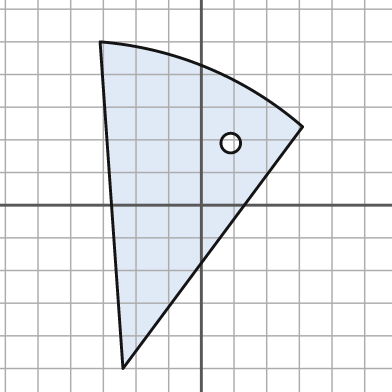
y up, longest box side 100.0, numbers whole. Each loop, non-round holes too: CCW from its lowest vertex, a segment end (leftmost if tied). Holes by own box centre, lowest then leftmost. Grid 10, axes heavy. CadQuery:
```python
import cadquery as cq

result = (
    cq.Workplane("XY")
    .moveTo(-24.0, -50.0)
    .lineTo(31.0, 24.0)
    .threePointArc((2.0, 42.0), (-31.0, 50.0))
    .close()
    .moveTo(9.0, 19.0)
    .circle(3.0)
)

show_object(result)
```